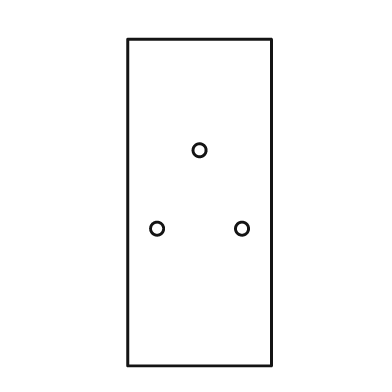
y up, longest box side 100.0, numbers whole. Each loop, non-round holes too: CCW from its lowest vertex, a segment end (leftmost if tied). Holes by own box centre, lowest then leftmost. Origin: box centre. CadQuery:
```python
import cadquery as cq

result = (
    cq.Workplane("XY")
    .moveTo(-22.0, -50.0)
    .lineTo(22.0, -50.0)
    .lineTo(22.0, 50.0)
    .lineTo(-22.0, 50.0)
    .close()
    .moveTo(-13.0, -8.0)
    .circle(2.0)
    .moveTo(13.0, -8.0)
    .circle(2.0)
    .moveTo(0.0, 16.0)
    .circle(2.0)
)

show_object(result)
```